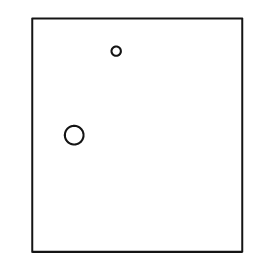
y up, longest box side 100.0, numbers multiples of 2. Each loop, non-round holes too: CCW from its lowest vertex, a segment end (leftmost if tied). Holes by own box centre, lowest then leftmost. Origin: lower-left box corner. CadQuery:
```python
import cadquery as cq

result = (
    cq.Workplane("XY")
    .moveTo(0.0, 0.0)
    .lineTo(90.0, 0.0)
    .lineTo(90.0, 100.0)
    .lineTo(0.0, 100.0)
    .close()
    .moveTo(18.0, 50.0)
    .circle(4.0)
    .moveTo(36.0, 86.0)
    .circle(2.0)
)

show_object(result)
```